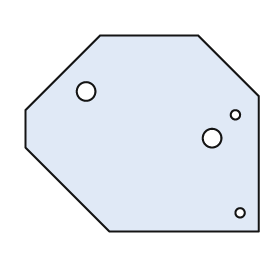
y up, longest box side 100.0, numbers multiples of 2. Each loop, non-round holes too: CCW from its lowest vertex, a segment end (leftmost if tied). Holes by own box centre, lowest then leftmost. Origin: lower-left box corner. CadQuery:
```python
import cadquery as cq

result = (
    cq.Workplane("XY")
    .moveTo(36.0, 0.0)
    .lineTo(100.0, 0.0)
    .lineTo(100.0, 58.0)
    .lineTo(74.0, 84.0)
    .lineTo(32.0, 84.0)
    .lineTo(0.0, 52.0)
    .lineTo(0.0, 36.0)
    .close()
    .moveTo(92.0, 8.0)
    .circle(2.0)
    .moveTo(80.0, 40.0)
    .circle(4.0)
    .moveTo(90.0, 50.0)
    .circle(2.0)
    .moveTo(26.0, 60.0)
    .circle(4.0)
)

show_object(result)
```